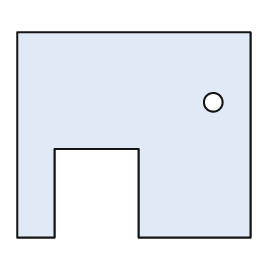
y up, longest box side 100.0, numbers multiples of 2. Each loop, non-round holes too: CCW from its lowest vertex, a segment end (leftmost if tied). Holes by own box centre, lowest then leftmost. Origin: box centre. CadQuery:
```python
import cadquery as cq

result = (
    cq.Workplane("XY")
    .moveTo(-50.0, -44.0)
    .lineTo(-34.0, -44.0)
    .lineTo(-34.0, -6.0)
    .lineTo(2.0, -6.0)
    .lineTo(2.0, -44.0)
    .lineTo(50.0, -44.0)
    .lineTo(50.0, 44.0)
    .lineTo(-50.0, 44.0)
    .close()
    .moveTo(34.0, 14.0)
    .circle(4.0)
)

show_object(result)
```